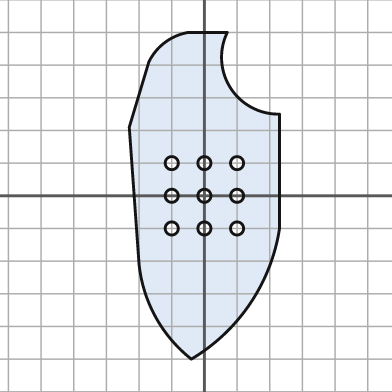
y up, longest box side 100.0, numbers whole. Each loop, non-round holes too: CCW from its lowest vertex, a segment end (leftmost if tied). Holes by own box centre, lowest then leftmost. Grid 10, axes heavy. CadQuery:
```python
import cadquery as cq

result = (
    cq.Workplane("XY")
    .moveTo(-4.0, -50.0)
    .threePointArc((14.0, -33.0), (23.0, -10.0))
    .lineTo(23.0, 25.0)
    .threePointArc((8.0, 33.0), (7.0, 50.0))
    .lineTo(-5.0, 50.0)
    .threePointArc((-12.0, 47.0), (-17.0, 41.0))
    .lineTo(-23.0, 21.0)
    .lineTo(-20.0, -21.0)
    .threePointArc((-15.0, -37.0), (-4.0, -50.0))
    .close()
    .moveTo(-10.0, -10.0)
    .circle(2.0)
    .moveTo(0.0, -10.0)
    .circle(2.0)
    .moveTo(10.0, -10.0)
    .circle(2.0)
    .moveTo(-10.0, 0.0)
    .circle(2.0)
    .moveTo(0.0, 0.0)
    .circle(2.0)
    .moveTo(10.0, 0.0)
    .circle(2.0)
    .moveTo(-10.0, 10.0)
    .circle(2.0)
    .moveTo(0.0, 10.0)
    .circle(2.0)
    .moveTo(10.0, 10.0)
    .circle(2.0)
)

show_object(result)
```